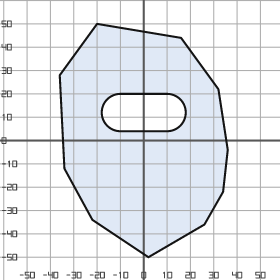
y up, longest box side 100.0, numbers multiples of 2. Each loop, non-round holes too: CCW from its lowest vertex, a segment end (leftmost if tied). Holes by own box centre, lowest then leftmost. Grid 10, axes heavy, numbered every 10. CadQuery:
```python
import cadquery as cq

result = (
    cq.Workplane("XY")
    .moveTo(2.0, -50.0)
    .lineTo(26.0, -36.0)
    .lineTo(34.0, -22.0)
    .lineTo(36.0, -4.0)
    .lineTo(32.0, 22.0)
    .lineTo(16.0, 44.0)
    .lineTo(-20.0, 50.0)
    .lineTo(-36.0, 28.0)
    .lineTo(-34.0, -12.0)
    .lineTo(-22.0, -34.0)
    .close()
    .moveTo(-10.0, 4.0)
    .lineTo(10.0, 4.0)
    .threePointArc((18.0, 12.0), (10.0, 20.0))
    .lineTo(-10.0, 20.0)
    .threePointArc((-18.0, 12.0), (-10.0, 4.0))
    .close()
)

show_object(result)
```